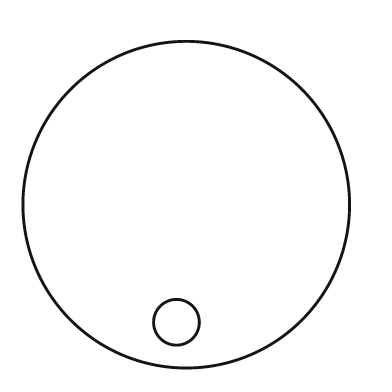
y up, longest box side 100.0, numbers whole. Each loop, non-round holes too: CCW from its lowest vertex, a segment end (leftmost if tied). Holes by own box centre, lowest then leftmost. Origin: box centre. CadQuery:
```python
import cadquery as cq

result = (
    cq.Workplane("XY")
    .moveTo(0.0, 0.0)
    .circle(50.0)
    .moveTo(-3.0, -36.0)
    .circle(7.0)
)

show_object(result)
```